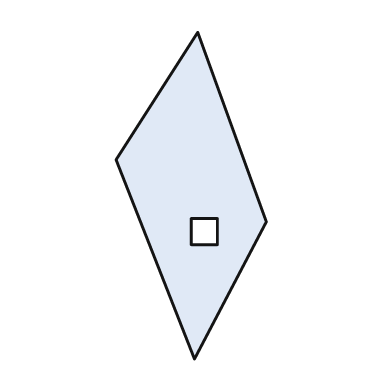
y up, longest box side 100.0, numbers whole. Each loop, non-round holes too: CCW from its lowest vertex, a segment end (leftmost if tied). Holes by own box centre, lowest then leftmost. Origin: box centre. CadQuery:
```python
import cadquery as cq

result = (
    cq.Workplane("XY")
    .moveTo(1.0, -50.0)
    .lineTo(23.0, -8.0)
    .lineTo(2.0, 50.0)
    .lineTo(-23.0, 11.0)
    .close()
    .moveTo(0.0, -15.0)
    .lineTo(8.0, -15.0)
    .lineTo(8.0, -7.0)
    .lineTo(0.0, -7.0)
    .close()
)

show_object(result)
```